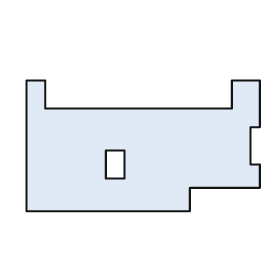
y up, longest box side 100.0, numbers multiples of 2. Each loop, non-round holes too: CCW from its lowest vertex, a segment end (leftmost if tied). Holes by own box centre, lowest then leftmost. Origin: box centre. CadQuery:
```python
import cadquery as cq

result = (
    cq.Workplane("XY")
    .moveTo(-50.0, -28.0)
    .lineTo(20.0, -28.0)
    .lineTo(20.0, -18.0)
    .lineTo(50.0, -18.0)
    .lineTo(50.0, -8.0)
    .lineTo(46.0, -8.0)
    .lineTo(46.0, 8.0)
    .lineTo(50.0, 8.0)
    .lineTo(50.0, 28.0)
    .lineTo(38.0, 28.0)
    .lineTo(38.0, 16.0)
    .lineTo(-42.0, 16.0)
    .lineTo(-42.0, 28.0)
    .lineTo(-50.0, 28.0)
    .close()
    .moveTo(-16.0, -14.0)
    .lineTo(-8.0, -14.0)
    .lineTo(-8.0, -2.0)
    .lineTo(-16.0, -2.0)
    .close()
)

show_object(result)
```